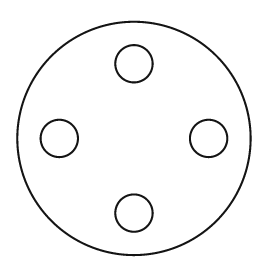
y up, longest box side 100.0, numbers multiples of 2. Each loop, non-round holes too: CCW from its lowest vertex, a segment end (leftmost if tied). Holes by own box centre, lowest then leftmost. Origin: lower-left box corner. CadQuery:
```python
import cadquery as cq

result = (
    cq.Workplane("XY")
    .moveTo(50.0, 50.0)
    .circle(50.0)
    .moveTo(50.0, 18.0)
    .circle(8.0)
    .moveTo(18.0, 50.0)
    .circle(8.0)
    .moveTo(82.0, 50.0)
    .circle(8.0)
    .moveTo(50.0, 82.0)
    .circle(8.0)
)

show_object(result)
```